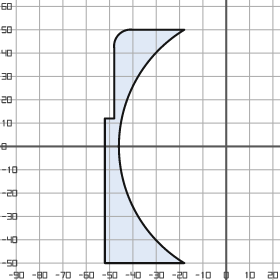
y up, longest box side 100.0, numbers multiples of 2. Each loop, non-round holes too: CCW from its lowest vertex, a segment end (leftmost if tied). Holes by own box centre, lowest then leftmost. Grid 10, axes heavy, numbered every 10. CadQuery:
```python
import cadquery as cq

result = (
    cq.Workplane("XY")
    .moveTo(-52.0, -50.0)
    .lineTo(-18.0, -50.0)
    .threePointArc((-46.0, 0.0), (-18.0, 50.0))
    .lineTo(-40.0, 50.0)
    .threePointArc((-46.0, 48.0), (-48.0, 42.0))
    .lineTo(-48.0, 12.0)
    .lineTo(-52.0, 12.0)
    .close()
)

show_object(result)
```